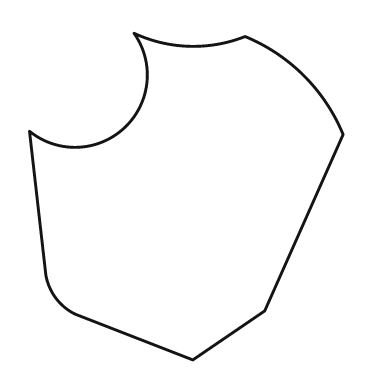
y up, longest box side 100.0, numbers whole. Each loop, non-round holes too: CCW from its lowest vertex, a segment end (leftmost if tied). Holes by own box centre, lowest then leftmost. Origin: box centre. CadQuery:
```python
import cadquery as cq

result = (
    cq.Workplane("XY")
    .moveTo(2.0, -50.0)
    .lineTo(24.0, -35.0)
    .lineTo(48.0, 19.0)
    .threePointArc((36.0, 37.0), (18.0, 49.0))
    .threePointArc((1.0, 46.0), (-16.0, 50.0))
    .threePointArc((-19.0, 21.0), (-48.0, 20.0))
    .lineTo(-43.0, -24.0)
    .threePointArc((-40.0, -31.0), (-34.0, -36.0))
    .close()
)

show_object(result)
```